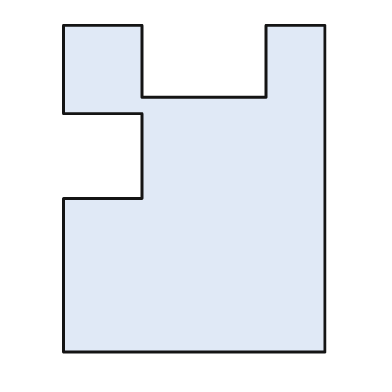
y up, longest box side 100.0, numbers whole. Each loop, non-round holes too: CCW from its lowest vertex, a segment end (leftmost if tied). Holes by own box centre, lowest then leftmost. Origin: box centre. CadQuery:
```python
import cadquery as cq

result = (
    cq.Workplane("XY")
    .moveTo(-40.0, -50.0)
    .lineTo(40.0, -50.0)
    .lineTo(40.0, 50.0)
    .lineTo(22.0, 50.0)
    .lineTo(22.0, 28.0)
    .lineTo(-16.0, 28.0)
    .lineTo(-16.0, 50.0)
    .lineTo(-40.0, 50.0)
    .lineTo(-40.0, 23.0)
    .lineTo(-16.0, 23.0)
    .lineTo(-16.0, -3.0)
    .lineTo(-40.0, -3.0)
    .close()
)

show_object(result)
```